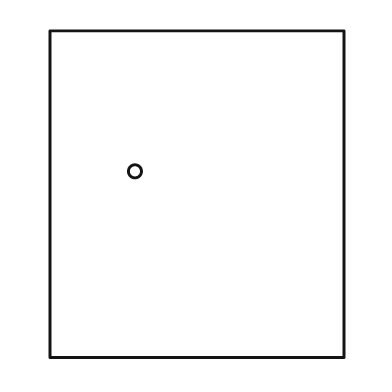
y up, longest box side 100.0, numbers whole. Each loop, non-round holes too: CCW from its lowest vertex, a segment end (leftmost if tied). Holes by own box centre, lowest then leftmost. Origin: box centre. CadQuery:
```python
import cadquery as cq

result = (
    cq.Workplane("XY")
    .moveTo(-45.0, -50.0)
    .lineTo(45.0, -50.0)
    .lineTo(45.0, 50.0)
    .lineTo(-45.0, 50.0)
    .close()
    .moveTo(-19.0, 7.0)
    .circle(2.0)
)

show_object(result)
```